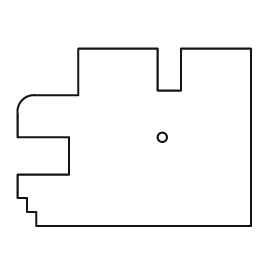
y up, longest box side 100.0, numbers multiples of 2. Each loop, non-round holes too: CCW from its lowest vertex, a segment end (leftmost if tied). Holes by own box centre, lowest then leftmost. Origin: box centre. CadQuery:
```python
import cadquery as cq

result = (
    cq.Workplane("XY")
    .moveTo(-42.0, -38.0)
    .lineTo(50.0, -38.0)
    .lineTo(50.0, 38.0)
    .lineTo(20.0, 38.0)
    .lineTo(20.0, 20.0)
    .lineTo(10.0, 20.0)
    .lineTo(10.0, 38.0)
    .lineTo(-24.0, 38.0)
    .lineTo(-24.0, 18.0)
    .lineTo(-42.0, 18.0)
    .threePointArc((-48.0, 16.0), (-50.0, 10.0))
    .lineTo(-50.0, 0.0)
    .lineTo(-28.0, 0.0)
    .lineTo(-28.0, -16.0)
    .lineTo(-50.0, -16.0)
    .lineTo(-50.0, -26.0)
    .lineTo(-46.0, -26.0)
    .lineTo(-46.0, -32.0)
    .lineTo(-42.0, -32.0)
    .close()
    .moveTo(12.0, 0.0)
    .circle(2.0)
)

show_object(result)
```